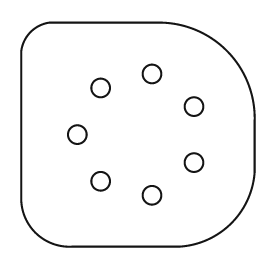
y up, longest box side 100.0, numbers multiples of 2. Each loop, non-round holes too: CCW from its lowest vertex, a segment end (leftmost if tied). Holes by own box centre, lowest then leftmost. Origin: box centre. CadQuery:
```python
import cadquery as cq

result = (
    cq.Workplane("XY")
    .moveTo(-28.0, -48.0)
    .lineTo(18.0, -48.0)
    .threePointArc((40.0, -38.0), (50.0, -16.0))
    .lineTo(50.0, 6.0)
    .threePointArc((38.0, 36.0), (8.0, 48.0))
    .lineTo(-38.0, 48.0)
    .threePointArc((-46.0, 44.0), (-50.0, 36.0))
    .lineTo(-50.0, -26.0)
    .threePointArc((-44.0, -42.0), (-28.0, -48.0))
    .close()
    .moveTo(6.0, -26.0)
    .circle(4.0)
    .moveTo(-16.0, -20.0)
    .circle(4.0)
    .moveTo(24.0, -12.0)
    .circle(4.0)
    .moveTo(-26.0, 0.0)
    .circle(4.0)
    .moveTo(24.0, 12.0)
    .circle(4.0)
    .moveTo(-16.0, 20.0)
    .circle(4.0)
    .moveTo(6.0, 26.0)
    .circle(4.0)
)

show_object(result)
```